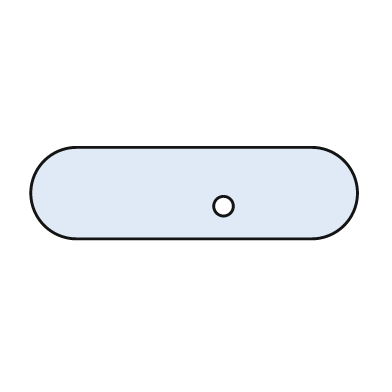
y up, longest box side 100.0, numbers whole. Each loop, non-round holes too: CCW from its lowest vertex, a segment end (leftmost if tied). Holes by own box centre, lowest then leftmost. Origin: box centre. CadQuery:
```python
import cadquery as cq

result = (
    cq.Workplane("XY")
    .moveTo(-36.0, -14.0)
    .lineTo(36.0, -14.0)
    .threePointArc((50.0, 0.0), (36.0, 14.0))
    .lineTo(-36.0, 14.0)
    .threePointArc((-50.0, 0.0), (-36.0, -14.0))
    .close()
    .moveTo(9.0, -4.0)
    .circle(3.0)
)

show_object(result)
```